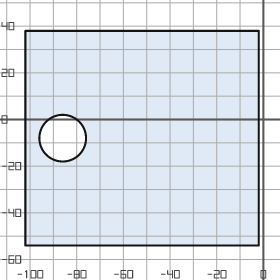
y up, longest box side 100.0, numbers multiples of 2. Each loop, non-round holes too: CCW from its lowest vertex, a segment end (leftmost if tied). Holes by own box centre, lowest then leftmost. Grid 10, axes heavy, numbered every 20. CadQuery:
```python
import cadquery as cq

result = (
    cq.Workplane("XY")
    .moveTo(-102.0, -54.0)
    .lineTo(-2.0, -54.0)
    .lineTo(-2.0, 38.0)
    .lineTo(-102.0, 38.0)
    .close()
    .moveTo(-86.0, -8.0)
    .circle(10.0)
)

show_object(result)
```